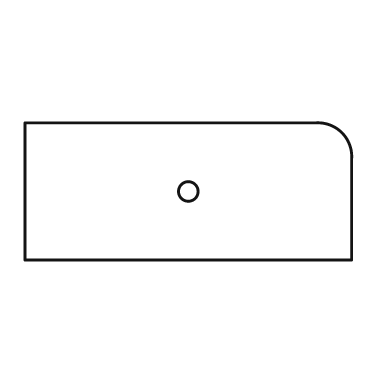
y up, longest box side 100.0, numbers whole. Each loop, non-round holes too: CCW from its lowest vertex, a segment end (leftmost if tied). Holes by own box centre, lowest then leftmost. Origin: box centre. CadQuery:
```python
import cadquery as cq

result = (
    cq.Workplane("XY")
    .moveTo(-50.0, -21.0)
    .lineTo(50.0, -21.0)
    .lineTo(50.0, 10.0)
    .threePointArc((47.0, 18.0), (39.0, 21.0))
    .lineTo(-50.0, 21.0)
    .close()
    .moveTo(0.0, 0.0)
    .circle(3.0)
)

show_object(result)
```